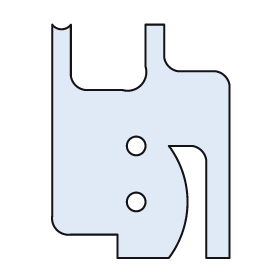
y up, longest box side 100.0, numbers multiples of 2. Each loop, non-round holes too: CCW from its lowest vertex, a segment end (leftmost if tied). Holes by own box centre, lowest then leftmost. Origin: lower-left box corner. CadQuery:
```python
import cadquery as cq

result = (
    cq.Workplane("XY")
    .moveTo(28.0, 0.0)
    .lineTo(50.0, 0.0)
    .threePointArc((58.0, 24.0), (50.0, 48.0))
    .lineTo(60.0, 48.0)
    .threePointArc((64.0, 46.0), (66.0, 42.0))
    .lineTo(66.0, 0.0)
    .lineTo(76.0, 0.0)
    .lineTo(76.0, 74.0)
    .threePointArc((74.0, 78.0), (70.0, 80.0))
    .lineTo(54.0, 80.0)
    .threePointArc((50.0, 82.0), (48.0, 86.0))
    .lineTo(48.0, 100.0)
    .lineTo(40.0, 100.0)
    .lineTo(40.0, 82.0)
    .threePointArc((38.0, 74.0), (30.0, 72.0))
    .lineTo(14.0, 72.0)
    .threePointArc((10.0, 74.0), (8.0, 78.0))
    .lineTo(8.0, 100.0)
    .threePointArc((4.0, 98.0), (0.0, 100.0))
    .lineTo(0.0, 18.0)
    .threePointArc((2.0, 12.0), (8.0, 10.0))
    .lineTo(28.0, 10.0)
    .close()
    .moveTo(36.0, 24.0)
    .circle(4.0)
    .moveTo(36.0, 48.0)
    .circle(4.0)
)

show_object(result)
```